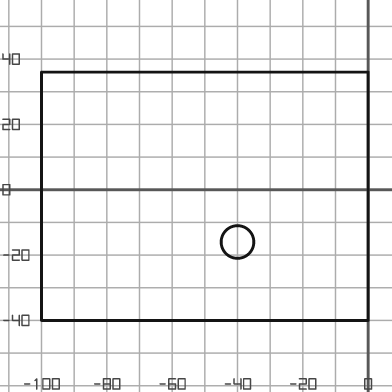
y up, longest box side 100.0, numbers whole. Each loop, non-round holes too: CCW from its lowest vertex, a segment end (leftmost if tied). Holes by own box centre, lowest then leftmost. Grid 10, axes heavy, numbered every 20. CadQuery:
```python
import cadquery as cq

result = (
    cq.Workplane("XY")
    .moveTo(-100.0, -40.0)
    .lineTo(0.0, -40.0)
    .lineTo(0.0, 36.0)
    .lineTo(-100.0, 36.0)
    .close()
    .moveTo(-40.0, -16.0)
    .circle(5.0)
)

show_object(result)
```